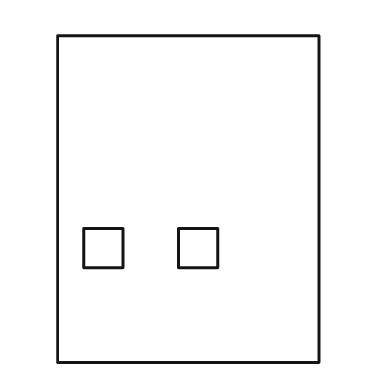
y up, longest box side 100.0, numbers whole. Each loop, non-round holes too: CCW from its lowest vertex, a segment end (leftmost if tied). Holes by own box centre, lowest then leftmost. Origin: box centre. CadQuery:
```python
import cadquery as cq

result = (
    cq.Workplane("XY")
    .moveTo(-40.0, -50.0)
    .lineTo(40.0, -50.0)
    .lineTo(40.0, 50.0)
    .lineTo(-40.0, 50.0)
    .close()
    .moveTo(-32.0, -21.0)
    .lineTo(-20.0, -21.0)
    .lineTo(-20.0, -9.0)
    .lineTo(-32.0, -9.0)
    .close()
    .moveTo(-3.0, -21.0)
    .lineTo(9.0, -21.0)
    .lineTo(9.0, -9.0)
    .lineTo(-3.0, -9.0)
    .close()
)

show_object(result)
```